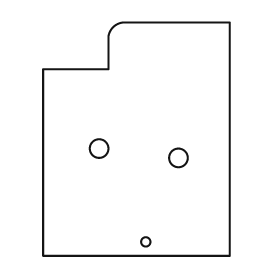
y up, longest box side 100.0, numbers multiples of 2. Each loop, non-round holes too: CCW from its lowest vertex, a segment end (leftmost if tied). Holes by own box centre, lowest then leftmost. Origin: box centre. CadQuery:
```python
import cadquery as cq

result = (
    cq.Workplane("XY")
    .moveTo(-40.0, -50.0)
    .lineTo(40.0, -50.0)
    .lineTo(40.0, 50.0)
    .lineTo(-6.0, 50.0)
    .threePointArc((-10.0, 48.0), (-12.0, 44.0))
    .lineTo(-12.0, 30.0)
    .lineTo(-40.0, 30.0)
    .close()
    .moveTo(4.0, -44.0)
    .circle(2.0)
    .moveTo(18.0, -8.0)
    .circle(4.0)
    .moveTo(-16.0, -4.0)
    .circle(4.0)
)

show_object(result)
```